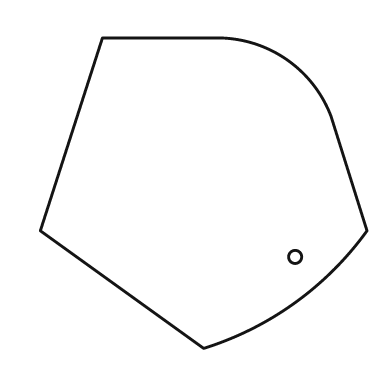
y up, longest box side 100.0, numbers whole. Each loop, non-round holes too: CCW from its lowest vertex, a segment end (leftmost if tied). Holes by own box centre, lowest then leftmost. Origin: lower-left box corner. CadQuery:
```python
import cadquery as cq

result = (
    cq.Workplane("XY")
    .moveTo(50.0, 0.0)
    .threePointArc((78.0, 14.0), (100.0, 36.0))
    .lineTo(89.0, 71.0)
    .threePointArc((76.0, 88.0), (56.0, 95.0))
    .lineTo(19.0, 95.0)
    .lineTo(0.0, 36.0)
    .close()
    .moveTo(78.0, 28.0)
    .circle(2.0)
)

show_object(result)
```